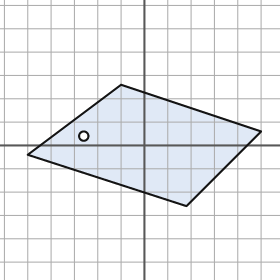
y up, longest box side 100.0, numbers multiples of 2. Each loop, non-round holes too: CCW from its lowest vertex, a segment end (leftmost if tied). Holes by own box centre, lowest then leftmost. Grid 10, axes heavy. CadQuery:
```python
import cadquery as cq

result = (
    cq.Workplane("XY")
    .moveTo(18.0, -26.0)
    .lineTo(50.0, 6.0)
    .lineTo(-10.0, 26.0)
    .lineTo(-50.0, -4.0)
    .close()
    .moveTo(-26.0, 4.0)
    .circle(2.0)
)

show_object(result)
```